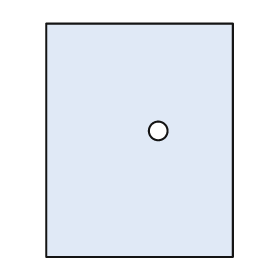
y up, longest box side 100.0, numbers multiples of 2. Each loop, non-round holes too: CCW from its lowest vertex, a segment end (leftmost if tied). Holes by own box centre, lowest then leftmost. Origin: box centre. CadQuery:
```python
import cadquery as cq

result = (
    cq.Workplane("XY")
    .moveTo(-40.0, -50.0)
    .lineTo(40.0, -50.0)
    .lineTo(40.0, 50.0)
    .lineTo(-40.0, 50.0)
    .close()
    .moveTo(8.0, 4.0)
    .circle(4.0)
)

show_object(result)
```